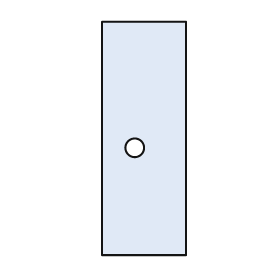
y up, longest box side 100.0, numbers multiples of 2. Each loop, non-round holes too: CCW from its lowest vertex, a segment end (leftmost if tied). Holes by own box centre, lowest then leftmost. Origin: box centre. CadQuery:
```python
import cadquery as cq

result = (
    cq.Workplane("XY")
    .moveTo(-18.0, -50.0)
    .lineTo(18.0, -50.0)
    .lineTo(18.0, 50.0)
    .lineTo(-18.0, 50.0)
    .close()
    .moveTo(-4.0, -4.0)
    .circle(4.0)
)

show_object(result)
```